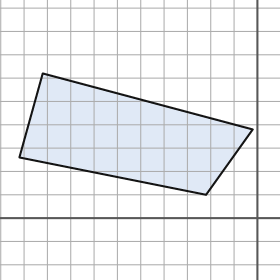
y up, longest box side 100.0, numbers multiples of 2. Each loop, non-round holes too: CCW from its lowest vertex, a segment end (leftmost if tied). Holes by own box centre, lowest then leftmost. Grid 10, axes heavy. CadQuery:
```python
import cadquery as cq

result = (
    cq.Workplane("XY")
    .moveTo(-22.0, 10.0)
    .lineTo(-2.0, 38.0)
    .lineTo(-92.0, 62.0)
    .lineTo(-102.0, 26.0)
    .close()
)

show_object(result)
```